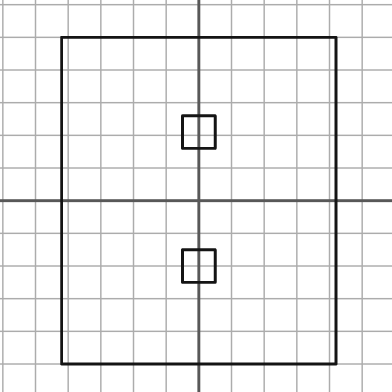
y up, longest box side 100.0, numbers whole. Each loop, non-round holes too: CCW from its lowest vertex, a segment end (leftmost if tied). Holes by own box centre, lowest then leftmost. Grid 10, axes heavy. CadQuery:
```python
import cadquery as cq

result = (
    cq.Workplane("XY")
    .moveTo(-42.0, -50.0)
    .lineTo(42.0, -50.0)
    .lineTo(42.0, 50.0)
    .lineTo(-42.0, 50.0)
    .close()
    .moveTo(-5.0, -25.0)
    .lineTo(5.0, -25.0)
    .lineTo(5.0, -15.0)
    .lineTo(-5.0, -15.0)
    .close()
    .moveTo(-5.0, 16.0)
    .lineTo(5.0, 16.0)
    .lineTo(5.0, 26.0)
    .lineTo(-5.0, 26.0)
    .close()
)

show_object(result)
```